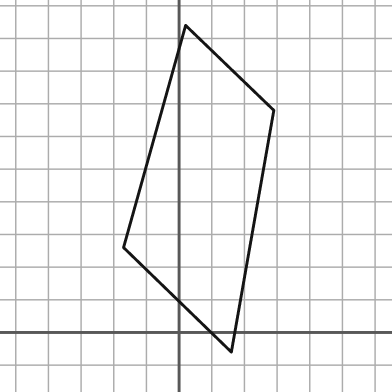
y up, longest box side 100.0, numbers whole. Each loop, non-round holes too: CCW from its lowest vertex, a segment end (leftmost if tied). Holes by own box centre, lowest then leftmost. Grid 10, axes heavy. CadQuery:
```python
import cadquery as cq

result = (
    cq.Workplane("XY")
    .moveTo(16.0, -6.0)
    .lineTo(29.0, 68.0)
    .lineTo(2.0, 94.0)
    .lineTo(-17.0, 26.0)
    .close()
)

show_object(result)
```